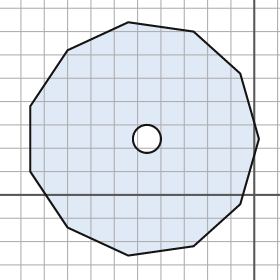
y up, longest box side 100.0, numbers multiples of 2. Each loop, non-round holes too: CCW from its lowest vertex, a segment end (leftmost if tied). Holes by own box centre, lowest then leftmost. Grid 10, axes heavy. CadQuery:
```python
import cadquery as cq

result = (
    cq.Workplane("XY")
    .moveTo(-54.0, -26.0)
    .lineTo(-26.0, -22.0)
    .lineTo(-6.0, -4.0)
    .lineTo(2.0, 24.0)
    .lineTo(-6.0, 52.0)
    .lineTo(-26.0, 70.0)
    .lineTo(-54.0, 74.0)
    .lineTo(-80.0, 62.0)
    .lineTo(-96.0, 38.0)
    .lineTo(-96.0, 10.0)
    .lineTo(-80.0, -14.0)
    .close()
    .moveTo(-46.0, 24.0)
    .circle(6.0)
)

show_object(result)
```